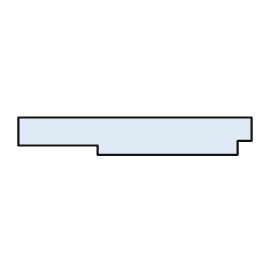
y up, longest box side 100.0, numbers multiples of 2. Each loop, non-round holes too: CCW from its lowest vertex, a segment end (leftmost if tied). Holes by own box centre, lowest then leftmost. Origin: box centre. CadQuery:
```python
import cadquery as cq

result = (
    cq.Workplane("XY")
    .moveTo(-16.0, -8.0)
    .lineTo(44.0, -8.0)
    .lineTo(44.0, -2.0)
    .lineTo(50.0, -2.0)
    .lineTo(50.0, 8.0)
    .lineTo(-50.0, 8.0)
    .lineTo(-50.0, -4.0)
    .lineTo(-16.0, -4.0)
    .close()
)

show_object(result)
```